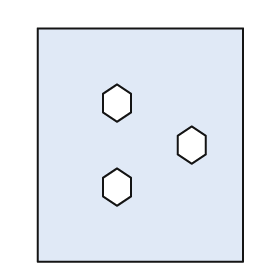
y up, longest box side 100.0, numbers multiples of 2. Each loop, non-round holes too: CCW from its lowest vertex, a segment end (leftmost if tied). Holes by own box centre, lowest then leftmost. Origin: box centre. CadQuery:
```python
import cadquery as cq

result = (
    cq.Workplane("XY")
    .moveTo(-44.0, -50.0)
    .lineTo(44.0, -50.0)
    .lineTo(44.0, 50.0)
    .lineTo(-44.0, 50.0)
    .close()
    .moveTo(-10.0, -26.0)
    .lineTo(-4.0, -22.0)
    .lineTo(-4.0, -14.0)
    .lineTo(-10.0, -10.0)
    .lineTo(-16.0, -14.0)
    .lineTo(-16.0, -22.0)
    .close()
    .moveTo(22.0, -8.0)
    .lineTo(28.0, -4.0)
    .lineTo(28.0, 4.0)
    .lineTo(22.0, 8.0)
    .lineTo(16.0, 4.0)
    .lineTo(16.0, -4.0)
    .close()
    .moveTo(-10.0, 10.0)
    .lineTo(-4.0, 14.0)
    .lineTo(-4.0, 22.0)
    .lineTo(-10.0, 26.0)
    .lineTo(-16.0, 22.0)
    .lineTo(-16.0, 14.0)
    .close()
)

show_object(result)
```